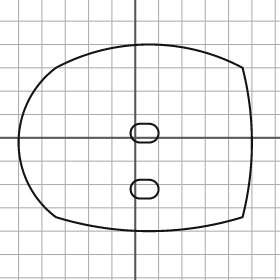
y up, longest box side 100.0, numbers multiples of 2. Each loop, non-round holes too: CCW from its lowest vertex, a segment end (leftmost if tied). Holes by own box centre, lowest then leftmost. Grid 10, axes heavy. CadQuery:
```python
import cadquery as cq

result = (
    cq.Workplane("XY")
    .moveTo(-34.0, -34.0)
    .threePointArc((6.0, -40.0), (46.0, -34.0))
    .threePointArc((50.0, -2.0), (46.0, 30.0))
    .threePointArc((6.0, 40.0), (-34.0, 30.0))
    .threePointArc((-50.0, -2.0), (-34.0, -34.0))
    .close()
    .moveTo(2.0, -26.0)
    .lineTo(6.0, -26.0)
    .threePointArc((10.0, -22.0), (6.0, -18.0))
    .lineTo(2.0, -18.0)
    .threePointArc((-2.0, -22.0), (2.0, -26.0))
    .close()
    .moveTo(2.0, -2.0)
    .lineTo(6.0, -2.0)
    .threePointArc((10.0, 2.0), (6.0, 6.0))
    .lineTo(2.0, 6.0)
    .threePointArc((-2.0, 2.0), (2.0, -2.0))
    .close()
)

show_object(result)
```